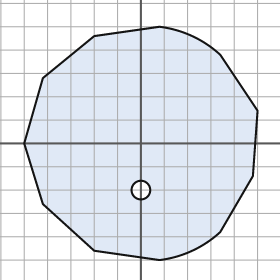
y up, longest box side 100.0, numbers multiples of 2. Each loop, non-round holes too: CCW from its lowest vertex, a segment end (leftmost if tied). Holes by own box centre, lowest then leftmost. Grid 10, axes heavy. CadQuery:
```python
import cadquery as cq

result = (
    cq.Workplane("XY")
    .moveTo(8.0, -50.0)
    .threePointArc((22.0, -46.0), (34.0, -38.0))
    .lineTo(48.0, -14.0)
    .lineTo(50.0, 14.0)
    .lineTo(34.0, 38.0)
    .threePointArc((22.0, 46.0), (8.0, 50.0))
    .lineTo(-20.0, 46.0)
    .lineTo(-42.0, 28.0)
    .lineTo(-50.0, 0.0)
    .lineTo(-42.0, -26.0)
    .lineTo(-20.0, -46.0)
    .close()
    .moveTo(0.0, -20.0)
    .circle(4.0)
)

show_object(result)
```